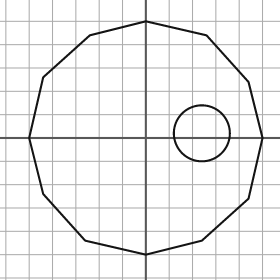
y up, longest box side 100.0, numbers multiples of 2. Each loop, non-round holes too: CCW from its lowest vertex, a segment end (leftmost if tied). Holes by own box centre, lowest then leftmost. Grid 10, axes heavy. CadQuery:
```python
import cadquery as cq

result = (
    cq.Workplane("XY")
    .moveTo(0.0, -50.0)
    .lineTo(24.0, -44.0)
    .lineTo(44.0, -26.0)
    .lineTo(50.0, 0.0)
    .lineTo(44.0, 24.0)
    .lineTo(26.0, 44.0)
    .lineTo(0.0, 50.0)
    .lineTo(-24.0, 44.0)
    .lineTo(-44.0, 26.0)
    .lineTo(-50.0, 0.0)
    .lineTo(-44.0, -24.0)
    .lineTo(-26.0, -44.0)
    .close()
    .moveTo(24.0, 2.0)
    .circle(12.0)
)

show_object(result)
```